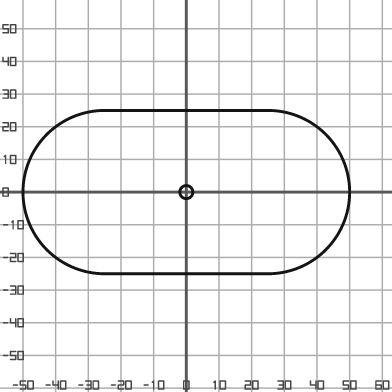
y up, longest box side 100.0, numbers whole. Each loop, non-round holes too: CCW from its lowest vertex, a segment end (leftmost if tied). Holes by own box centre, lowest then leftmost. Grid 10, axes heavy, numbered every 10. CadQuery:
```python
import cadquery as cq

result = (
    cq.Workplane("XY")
    .moveTo(-25.0, -25.0)
    .lineTo(25.0, -25.0)
    .threePointArc((50.0, 0.0), (25.0, 25.0))
    .lineTo(-25.0, 25.0)
    .threePointArc((-50.0, 0.0), (-25.0, -25.0))
    .close()
    .moveTo(0.0, 0.0)
    .circle(2.0)
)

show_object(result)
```